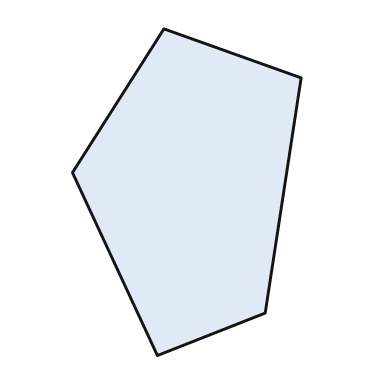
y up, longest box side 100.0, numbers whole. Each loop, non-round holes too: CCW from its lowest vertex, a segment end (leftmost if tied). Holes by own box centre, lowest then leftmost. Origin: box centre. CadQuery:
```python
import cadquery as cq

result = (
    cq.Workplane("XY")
    .moveTo(-9.0, -50.0)
    .lineTo(24.0, -37.0)
    .lineTo(35.0, 35.0)
    .lineTo(-7.0, 50.0)
    .lineTo(-35.0, 6.0)
    .close()
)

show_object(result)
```